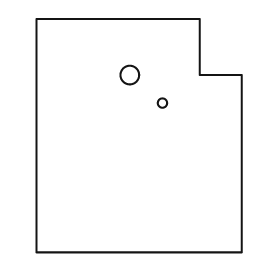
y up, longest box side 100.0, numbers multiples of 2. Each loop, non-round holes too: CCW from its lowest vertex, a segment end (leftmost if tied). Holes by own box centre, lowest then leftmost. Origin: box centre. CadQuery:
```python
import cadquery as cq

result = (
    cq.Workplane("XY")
    .moveTo(-44.0, -50.0)
    .lineTo(44.0, -50.0)
    .lineTo(44.0, 26.0)
    .lineTo(26.0, 26.0)
    .lineTo(26.0, 50.0)
    .lineTo(-44.0, 50.0)
    .close()
    .moveTo(10.0, 14.0)
    .circle(2.0)
    .moveTo(-4.0, 26.0)
    .circle(4.0)
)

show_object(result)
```